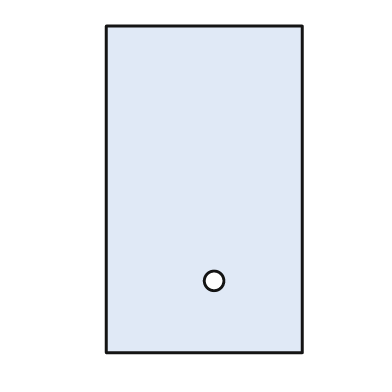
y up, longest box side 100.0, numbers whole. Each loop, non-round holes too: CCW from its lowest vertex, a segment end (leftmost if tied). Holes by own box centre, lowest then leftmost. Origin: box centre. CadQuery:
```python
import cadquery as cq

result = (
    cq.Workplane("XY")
    .moveTo(-30.0, -50.0)
    .lineTo(30.0, -50.0)
    .lineTo(30.0, 50.0)
    .lineTo(-30.0, 50.0)
    .close()
    .moveTo(3.0, -28.0)
    .circle(3.0)
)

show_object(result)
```